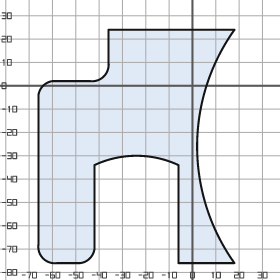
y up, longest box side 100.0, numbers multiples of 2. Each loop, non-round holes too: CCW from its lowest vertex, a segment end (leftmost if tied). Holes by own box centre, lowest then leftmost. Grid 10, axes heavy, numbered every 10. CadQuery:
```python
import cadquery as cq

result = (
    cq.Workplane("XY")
    .moveTo(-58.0, -76.0)
    .lineTo(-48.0, -76.0)
    .threePointArc((-44.0, -74.0), (-42.0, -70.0))
    .lineTo(-42.0, -34.0)
    .threePointArc((-24.0, -30.0), (-6.0, -34.0))
    .lineTo(-6.0, -76.0)
    .lineTo(18.0, -76.0)
    .threePointArc((2.0, -26.0), (18.0, 24.0))
    .lineTo(-36.0, 24.0)
    .lineTo(-36.0, 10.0)
    .threePointArc((-38.0, 4.0), (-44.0, 2.0))
    .lineTo(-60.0, 2.0)
    .threePointArc((-64.0, 0.0), (-66.0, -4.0))
    .lineTo(-66.0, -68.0)
    .threePointArc((-64.0, -74.0), (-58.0, -76.0))
    .close()
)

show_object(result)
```